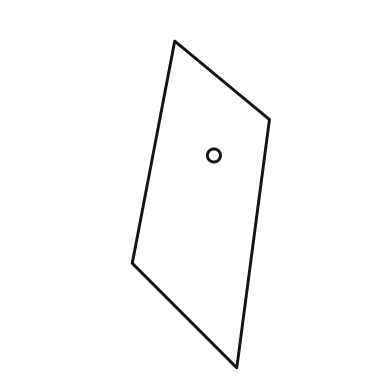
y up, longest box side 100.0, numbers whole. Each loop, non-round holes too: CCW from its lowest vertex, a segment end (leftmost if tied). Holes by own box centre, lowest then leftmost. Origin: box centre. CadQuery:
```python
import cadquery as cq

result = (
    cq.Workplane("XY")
    .moveTo(11.0, -50.0)
    .lineTo(21.0, 26.0)
    .lineTo(-8.0, 50.0)
    .lineTo(-21.0, -18.0)
    .close()
    .moveTo(4.0, 15.0)
    .circle(2.0)
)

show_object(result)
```